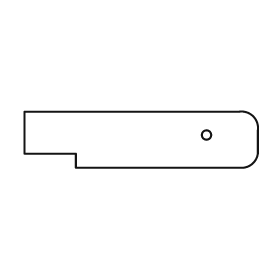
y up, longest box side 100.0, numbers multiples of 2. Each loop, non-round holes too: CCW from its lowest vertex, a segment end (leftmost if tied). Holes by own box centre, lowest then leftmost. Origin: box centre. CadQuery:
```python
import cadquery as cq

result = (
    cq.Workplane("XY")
    .moveTo(-28.0, -12.0)
    .lineTo(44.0, -12.0)
    .threePointArc((48.0, -10.0), (50.0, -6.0))
    .lineTo(50.0, 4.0)
    .threePointArc((48.0, 10.0), (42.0, 12.0))
    .lineTo(-50.0, 12.0)
    .lineTo(-50.0, -6.0)
    .lineTo(-28.0, -6.0)
    .close()
    .moveTo(28.0, 2.0)
    .circle(2.0)
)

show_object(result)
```